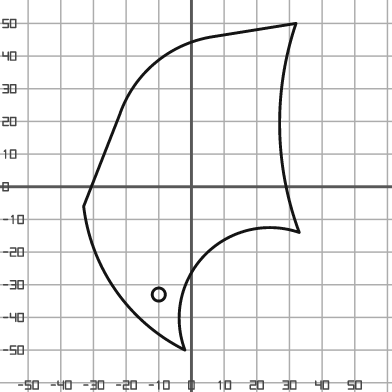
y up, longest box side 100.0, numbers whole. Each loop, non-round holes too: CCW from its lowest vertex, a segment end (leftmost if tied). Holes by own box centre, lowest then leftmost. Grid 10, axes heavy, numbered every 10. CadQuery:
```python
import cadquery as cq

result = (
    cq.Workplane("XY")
    .moveTo(-2.0, -50.0)
    .threePointArc((4.0, -21.0), (33.0, -14.0))
    .threePointArc((27.0, 18.0), (32.0, 50.0))
    .lineTo(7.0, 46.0)
    .threePointArc((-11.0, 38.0), (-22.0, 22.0))
    .lineTo(-33.0, -6.0)
    .threePointArc((-23.0, -32.0), (-2.0, -50.0))
    .close()
    .moveTo(-10.0, -33.0)
    .circle(2.0)
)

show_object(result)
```